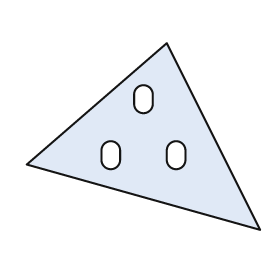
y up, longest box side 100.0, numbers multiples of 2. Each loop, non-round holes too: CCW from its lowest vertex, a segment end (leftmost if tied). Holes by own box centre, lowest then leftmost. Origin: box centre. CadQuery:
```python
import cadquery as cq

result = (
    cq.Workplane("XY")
    .moveTo(50.0, -40.0)
    .lineTo(10.0, 40.0)
    .lineTo(-50.0, -12.0)
    .close()
    .moveTo(-18.0, -10.0)
    .threePointArc((-14.0, -14.0), (-10.0, -10.0))
    .lineTo(-10.0, -6.0)
    .threePointArc((-14.0, -2.0), (-18.0, -6.0))
    .close()
    .moveTo(10.0, -10.0)
    .threePointArc((14.0, -14.0), (18.0, -10.0))
    .lineTo(18.0, -6.0)
    .threePointArc((14.0, -2.0), (10.0, -6.0))
    .close()
    .moveTo(-4.0, 14.0)
    .threePointArc((0.0, 10.0), (4.0, 14.0))
    .lineTo(4.0, 18.0)
    .threePointArc((0.0, 22.0), (-4.0, 18.0))
    .close()
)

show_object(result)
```